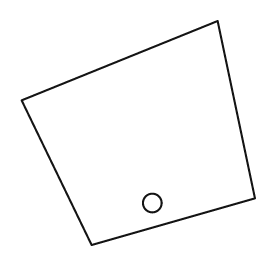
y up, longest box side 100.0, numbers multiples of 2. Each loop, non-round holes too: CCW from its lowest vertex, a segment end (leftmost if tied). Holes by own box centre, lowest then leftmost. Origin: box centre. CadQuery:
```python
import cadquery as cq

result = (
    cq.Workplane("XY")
    .moveTo(-20.0, -48.0)
    .lineTo(50.0, -28.0)
    .lineTo(34.0, 48.0)
    .lineTo(-50.0, 14.0)
    .close()
    .moveTo(6.0, -30.0)
    .circle(4.0)
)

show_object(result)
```